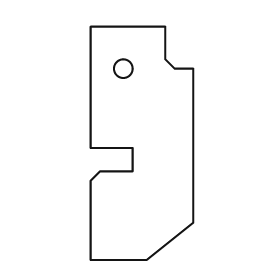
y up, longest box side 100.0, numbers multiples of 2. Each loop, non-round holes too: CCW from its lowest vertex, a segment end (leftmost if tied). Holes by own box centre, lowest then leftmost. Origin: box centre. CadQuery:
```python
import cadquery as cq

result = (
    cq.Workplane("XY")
    .moveTo(-22.0, -50.0)
    .lineTo(2.0, -50.0)
    .lineTo(22.0, -34.0)
    .lineTo(22.0, 32.0)
    .lineTo(14.0, 32.0)
    .lineTo(10.0, 36.0)
    .lineTo(10.0, 50.0)
    .lineTo(-22.0, 50.0)
    .lineTo(-22.0, -2.0)
    .lineTo(-4.0, -2.0)
    .lineTo(-4.0, -12.0)
    .lineTo(-18.0, -12.0)
    .lineTo(-22.0, -16.0)
    .close()
    .moveTo(-8.0, 32.0)
    .circle(4.0)
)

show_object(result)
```